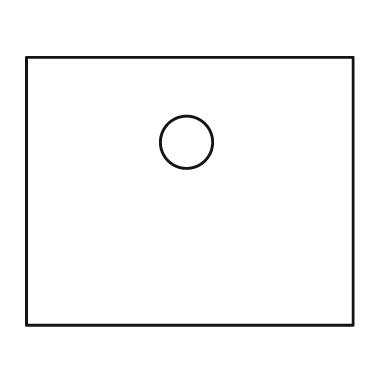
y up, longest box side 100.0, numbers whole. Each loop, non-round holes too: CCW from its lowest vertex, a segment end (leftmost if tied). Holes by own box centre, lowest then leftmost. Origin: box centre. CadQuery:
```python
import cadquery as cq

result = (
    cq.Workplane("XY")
    .moveTo(-50.0, -41.0)
    .lineTo(50.0, -41.0)
    .lineTo(50.0, 41.0)
    .lineTo(-50.0, 41.0)
    .close()
    .moveTo(-1.0, 15.0)
    .circle(8.0)
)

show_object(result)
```